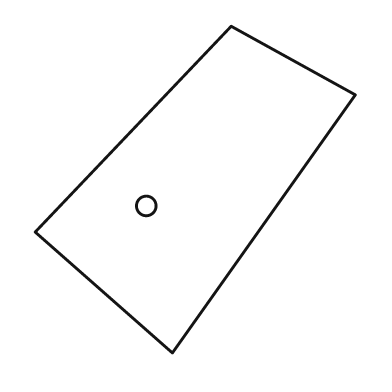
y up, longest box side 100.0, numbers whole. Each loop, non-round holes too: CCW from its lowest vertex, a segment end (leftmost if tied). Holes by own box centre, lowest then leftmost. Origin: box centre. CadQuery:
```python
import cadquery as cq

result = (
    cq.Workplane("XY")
    .moveTo(-7.0, -50.0)
    .lineTo(49.0, 29.0)
    .lineTo(11.0, 50.0)
    .lineTo(-49.0, -13.0)
    .close()
    .moveTo(-15.0, -5.0)
    .circle(3.0)
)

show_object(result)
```